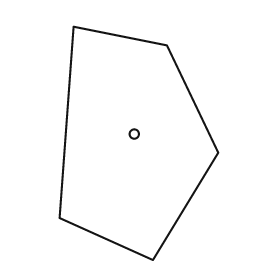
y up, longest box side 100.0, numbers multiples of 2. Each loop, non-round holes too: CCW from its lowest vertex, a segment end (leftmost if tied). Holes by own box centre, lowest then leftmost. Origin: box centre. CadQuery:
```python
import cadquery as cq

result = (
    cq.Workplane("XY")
    .moveTo(6.0, -50.0)
    .lineTo(34.0, -4.0)
    .lineTo(12.0, 42.0)
    .lineTo(-28.0, 50.0)
    .lineTo(-34.0, -32.0)
    .close()
    .moveTo(-2.0, 4.0)
    .circle(2.0)
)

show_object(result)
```